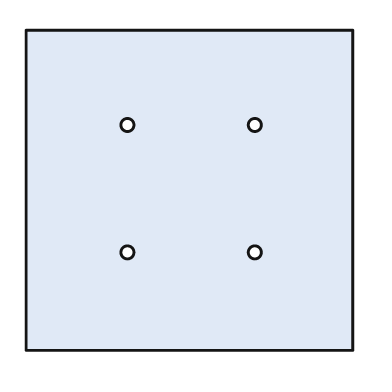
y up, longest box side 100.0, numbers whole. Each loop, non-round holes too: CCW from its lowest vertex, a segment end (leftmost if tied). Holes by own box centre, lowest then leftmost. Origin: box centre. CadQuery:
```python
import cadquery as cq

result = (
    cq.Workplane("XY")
    .moveTo(-50.0, -49.0)
    .lineTo(50.0, -49.0)
    .lineTo(50.0, 49.0)
    .lineTo(-50.0, 49.0)
    .close()
    .moveTo(-19.0, -19.0)
    .circle(2.0)
    .moveTo(20.0, -19.0)
    .circle(2.0)
    .moveTo(-19.0, 20.0)
    .circle(2.0)
    .moveTo(20.0, 20.0)
    .circle(2.0)
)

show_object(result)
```